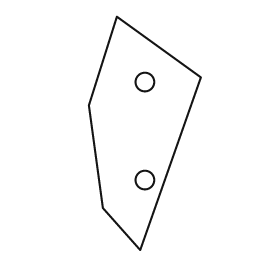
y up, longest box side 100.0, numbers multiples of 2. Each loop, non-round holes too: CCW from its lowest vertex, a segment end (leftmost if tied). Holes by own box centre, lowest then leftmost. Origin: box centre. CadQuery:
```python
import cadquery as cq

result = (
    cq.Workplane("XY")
    .moveTo(-2.0, -50.0)
    .lineTo(24.0, 24.0)
    .lineTo(-12.0, 50.0)
    .lineTo(-24.0, 12.0)
    .lineTo(-18.0, -32.0)
    .close()
    .moveTo(0.0, -20.0)
    .circle(4.0)
    .moveTo(0.0, 22.0)
    .circle(4.0)
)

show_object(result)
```